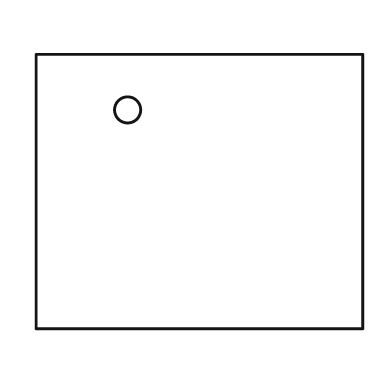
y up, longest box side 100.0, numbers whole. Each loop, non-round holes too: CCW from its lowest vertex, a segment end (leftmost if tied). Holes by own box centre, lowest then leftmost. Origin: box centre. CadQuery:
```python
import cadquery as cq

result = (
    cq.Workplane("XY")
    .moveTo(-50.0, -42.0)
    .lineTo(50.0, -42.0)
    .lineTo(50.0, 42.0)
    .lineTo(-50.0, 42.0)
    .close()
    .moveTo(-22.0, 25.0)
    .circle(4.0)
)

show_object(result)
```